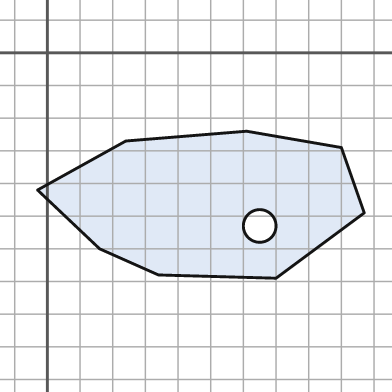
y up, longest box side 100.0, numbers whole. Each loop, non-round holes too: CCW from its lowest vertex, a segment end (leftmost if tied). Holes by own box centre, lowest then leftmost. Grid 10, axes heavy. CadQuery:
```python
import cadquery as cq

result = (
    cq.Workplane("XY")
    .moveTo(70.0, -69.0)
    .lineTo(97.0, -49.0)
    .lineTo(90.0, -29.0)
    .lineTo(61.0, -24.0)
    .lineTo(24.0, -27.0)
    .lineTo(-3.0, -42.0)
    .lineTo(16.0, -60.0)
    .lineTo(34.0, -68.0)
    .close()
    .moveTo(65.0, -53.0)
    .circle(5.0)
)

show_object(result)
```